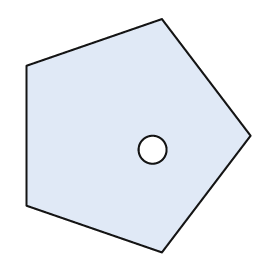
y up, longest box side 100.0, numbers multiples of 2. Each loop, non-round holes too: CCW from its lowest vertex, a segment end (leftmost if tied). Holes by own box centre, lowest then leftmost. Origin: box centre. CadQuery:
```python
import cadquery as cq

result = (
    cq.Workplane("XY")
    .moveTo(10.0, -50.0)
    .lineTo(48.0, 0.0)
    .lineTo(10.0, 50.0)
    .lineTo(-48.0, 30.0)
    .lineTo(-48.0, -30.0)
    .close()
    .moveTo(6.0, -6.0)
    .circle(6.0)
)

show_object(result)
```